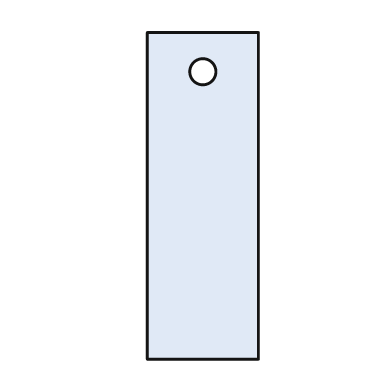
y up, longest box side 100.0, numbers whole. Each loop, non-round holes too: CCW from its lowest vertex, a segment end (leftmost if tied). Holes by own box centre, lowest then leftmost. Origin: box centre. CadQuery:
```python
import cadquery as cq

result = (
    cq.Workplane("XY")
    .moveTo(-17.0, -50.0)
    .lineTo(17.0, -50.0)
    .lineTo(17.0, 50.0)
    .lineTo(-17.0, 50.0)
    .close()
    .moveTo(0.0, 38.0)
    .circle(4.0)
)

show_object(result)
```